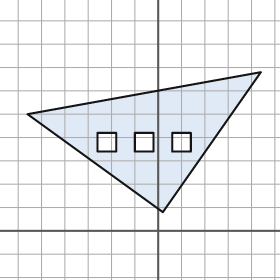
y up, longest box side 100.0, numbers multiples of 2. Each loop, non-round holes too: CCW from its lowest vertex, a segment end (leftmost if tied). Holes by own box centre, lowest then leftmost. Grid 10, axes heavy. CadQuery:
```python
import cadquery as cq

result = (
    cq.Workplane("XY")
    .moveTo(2.0, 8.0)
    .lineTo(44.0, 68.0)
    .lineTo(-56.0, 50.0)
    .close()
    .moveTo(-26.0, 34.0)
    .lineTo(-18.0, 34.0)
    .lineTo(-18.0, 42.0)
    .lineTo(-26.0, 42.0)
    .close()
    .moveTo(-10.0, 34.0)
    .lineTo(-2.0, 34.0)
    .lineTo(-2.0, 42.0)
    .lineTo(-10.0, 42.0)
    .close()
    .moveTo(6.0, 34.0)
    .lineTo(14.0, 34.0)
    .lineTo(14.0, 42.0)
    .lineTo(6.0, 42.0)
    .close()
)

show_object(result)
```